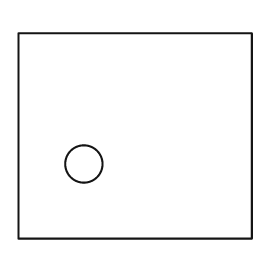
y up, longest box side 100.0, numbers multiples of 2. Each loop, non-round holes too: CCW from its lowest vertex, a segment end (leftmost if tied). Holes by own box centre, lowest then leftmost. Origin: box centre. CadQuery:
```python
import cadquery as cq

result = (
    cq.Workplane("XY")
    .moveTo(-50.0, -44.0)
    .lineTo(50.0, -44.0)
    .lineTo(50.0, 44.0)
    .lineTo(-50.0, 44.0)
    .close()
    .moveTo(-22.0, -12.0)
    .circle(8.0)
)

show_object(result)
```